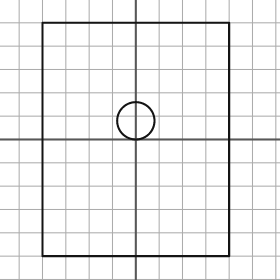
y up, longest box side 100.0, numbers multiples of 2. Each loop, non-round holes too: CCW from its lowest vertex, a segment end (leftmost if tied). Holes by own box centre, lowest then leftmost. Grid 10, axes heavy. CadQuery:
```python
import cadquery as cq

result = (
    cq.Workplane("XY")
    .moveTo(-40.0, -50.0)
    .lineTo(40.0, -50.0)
    .lineTo(40.0, 50.0)
    .lineTo(-40.0, 50.0)
    .close()
    .moveTo(0.0, 8.0)
    .circle(8.0)
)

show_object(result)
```